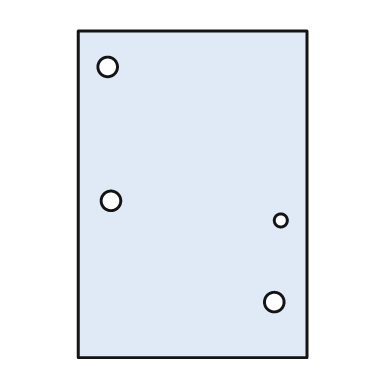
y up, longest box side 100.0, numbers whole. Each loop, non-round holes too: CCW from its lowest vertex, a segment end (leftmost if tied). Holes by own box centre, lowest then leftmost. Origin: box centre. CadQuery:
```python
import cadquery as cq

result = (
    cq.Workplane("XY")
    .moveTo(-35.0, -50.0)
    .lineTo(35.0, -50.0)
    .lineTo(35.0, 50.0)
    .lineTo(-35.0, 50.0)
    .close()
    .moveTo(25.0, -33.0)
    .circle(3.0)
    .moveTo(27.0, -8.0)
    .circle(2.0)
    .moveTo(-25.0, -2.0)
    .circle(3.0)
    .moveTo(-26.0, 39.0)
    .circle(3.0)
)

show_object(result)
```